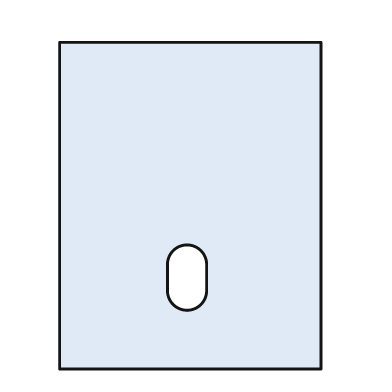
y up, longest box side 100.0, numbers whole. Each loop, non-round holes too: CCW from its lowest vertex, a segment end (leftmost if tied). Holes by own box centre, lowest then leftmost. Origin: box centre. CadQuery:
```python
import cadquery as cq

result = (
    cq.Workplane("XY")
    .moveTo(-40.0, -50.0)
    .lineTo(40.0, -50.0)
    .lineTo(40.0, 50.0)
    .lineTo(-40.0, 50.0)
    .close()
    .moveTo(-7.0, -26.0)
    .threePointArc((-1.0, -32.0), (5.0, -26.0))
    .lineTo(5.0, -18.0)
    .threePointArc((-1.0, -12.0), (-7.0, -18.0))
    .close()
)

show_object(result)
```